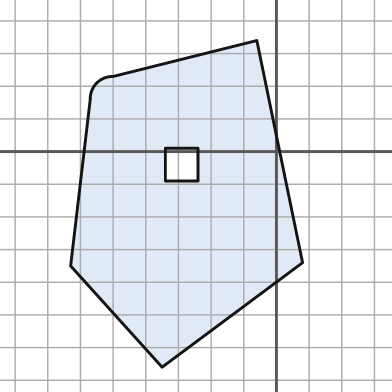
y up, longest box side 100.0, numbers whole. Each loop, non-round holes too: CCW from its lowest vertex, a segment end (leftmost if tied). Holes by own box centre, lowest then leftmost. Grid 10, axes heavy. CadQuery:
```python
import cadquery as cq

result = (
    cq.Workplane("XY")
    .moveTo(-35.0, -66.0)
    .lineTo(8.0, -34.0)
    .lineTo(-6.0, 34.0)
    .lineTo(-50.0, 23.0)
    .threePointArc((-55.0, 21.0), (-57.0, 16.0))
    .lineTo(-63.0, -35.0)
    .close()
    .moveTo(-34.0, -9.0)
    .lineTo(-24.0, -9.0)
    .lineTo(-24.0, 1.0)
    .lineTo(-34.0, 1.0)
    .close()
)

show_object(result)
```